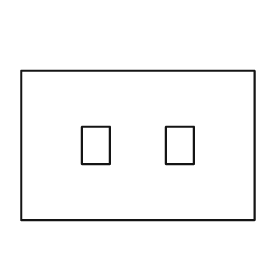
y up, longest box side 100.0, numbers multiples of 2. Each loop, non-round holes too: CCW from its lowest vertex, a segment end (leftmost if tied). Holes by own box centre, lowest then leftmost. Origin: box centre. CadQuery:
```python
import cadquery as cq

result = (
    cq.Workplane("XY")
    .moveTo(-50.0, -32.0)
    .lineTo(50.0, -32.0)
    .lineTo(50.0, 32.0)
    .lineTo(-50.0, 32.0)
    .close()
    .moveTo(-24.0, -8.0)
    .lineTo(-12.0, -8.0)
    .lineTo(-12.0, 8.0)
    .lineTo(-24.0, 8.0)
    .close()
    .moveTo(12.0, -8.0)
    .lineTo(24.0, -8.0)
    .lineTo(24.0, 8.0)
    .lineTo(12.0, 8.0)
    .close()
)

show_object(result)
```